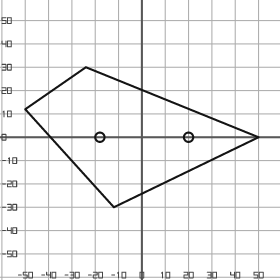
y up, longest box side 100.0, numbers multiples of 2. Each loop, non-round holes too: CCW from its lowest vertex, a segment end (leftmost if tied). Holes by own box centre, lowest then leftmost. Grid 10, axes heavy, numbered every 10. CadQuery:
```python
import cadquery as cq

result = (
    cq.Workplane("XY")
    .moveTo(-12.0, -30.0)
    .lineTo(50.0, 0.0)
    .lineTo(-24.0, 30.0)
    .lineTo(-50.0, 12.0)
    .close()
    .moveTo(-18.0, 0.0)
    .circle(2.0)
    .moveTo(20.0, 0.0)
    .circle(2.0)
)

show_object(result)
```